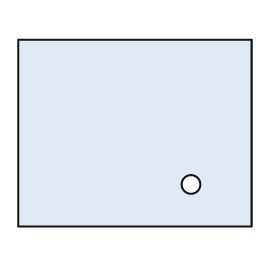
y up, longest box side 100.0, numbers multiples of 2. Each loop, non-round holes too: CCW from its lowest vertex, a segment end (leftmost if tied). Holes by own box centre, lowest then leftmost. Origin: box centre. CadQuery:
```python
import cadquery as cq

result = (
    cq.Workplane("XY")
    .moveTo(-50.0, -40.0)
    .lineTo(50.0, -40.0)
    .lineTo(50.0, 40.0)
    .lineTo(-50.0, 40.0)
    .close()
    .moveTo(24.0, -22.0)
    .circle(4.0)
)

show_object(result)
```